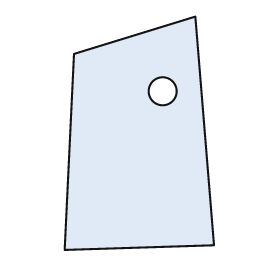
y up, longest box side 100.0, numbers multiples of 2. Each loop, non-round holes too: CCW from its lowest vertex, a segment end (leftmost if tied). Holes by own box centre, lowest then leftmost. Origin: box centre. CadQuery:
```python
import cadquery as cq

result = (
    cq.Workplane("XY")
    .moveTo(-32.0, -50.0)
    .lineTo(32.0, -48.0)
    .lineTo(24.0, 50.0)
    .lineTo(-28.0, 34.0)
    .close()
    .moveTo(10.0, 18.0)
    .circle(6.0)
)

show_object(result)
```